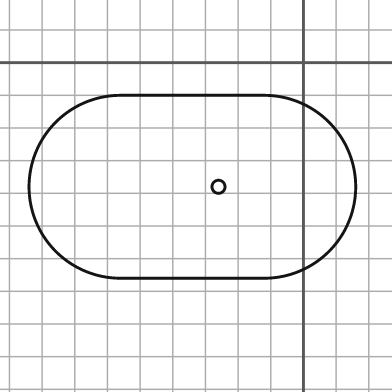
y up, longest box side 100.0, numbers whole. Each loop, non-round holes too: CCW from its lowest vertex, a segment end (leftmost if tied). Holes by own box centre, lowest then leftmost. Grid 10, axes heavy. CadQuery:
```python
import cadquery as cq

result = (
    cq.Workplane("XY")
    .moveTo(-56.0, -66.0)
    .lineTo(-12.0, -66.0)
    .threePointArc((16.0, -38.0), (-12.0, -10.0))
    .lineTo(-56.0, -10.0)
    .threePointArc((-84.0, -38.0), (-56.0, -66.0))
    .close()
    .moveTo(-26.0, -38.0)
    .circle(2.0)
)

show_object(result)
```